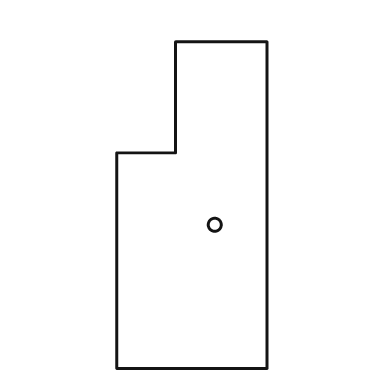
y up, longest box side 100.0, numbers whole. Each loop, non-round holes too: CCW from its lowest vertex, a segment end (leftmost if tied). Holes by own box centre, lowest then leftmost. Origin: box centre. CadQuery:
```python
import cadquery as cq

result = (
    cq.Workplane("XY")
    .moveTo(-23.0, -50.0)
    .lineTo(23.0, -50.0)
    .lineTo(23.0, 50.0)
    .lineTo(-5.0, 50.0)
    .lineTo(-5.0, 16.0)
    .lineTo(-23.0, 16.0)
    .close()
    .moveTo(7.0, -6.0)
    .circle(2.0)
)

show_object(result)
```